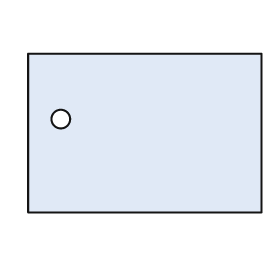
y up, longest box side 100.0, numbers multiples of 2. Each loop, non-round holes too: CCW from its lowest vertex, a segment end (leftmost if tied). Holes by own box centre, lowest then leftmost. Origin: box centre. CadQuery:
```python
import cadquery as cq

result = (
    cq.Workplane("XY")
    .moveTo(-50.0, -34.0)
    .lineTo(50.0, -34.0)
    .lineTo(50.0, 34.0)
    .lineTo(-50.0, 34.0)
    .close()
    .moveTo(-36.0, 6.0)
    .circle(4.0)
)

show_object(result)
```